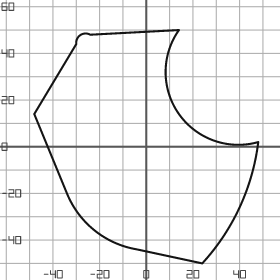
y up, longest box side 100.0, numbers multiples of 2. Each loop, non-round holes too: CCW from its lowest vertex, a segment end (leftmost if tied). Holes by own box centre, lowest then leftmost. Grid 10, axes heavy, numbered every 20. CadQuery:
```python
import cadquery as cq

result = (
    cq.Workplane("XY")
    .moveTo(24.0, -50.0)
    .threePointArc((40.0, -26.0), (48.0, 2.0))
    .threePointArc((14.0, 14.0), (14.0, 50.0))
    .lineTo(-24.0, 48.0)
    .threePointArc((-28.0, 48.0), (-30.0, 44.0))
    .lineTo(-48.0, 14.0)
    .lineTo(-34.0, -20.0)
    .threePointArc((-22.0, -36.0), (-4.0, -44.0))
    .close()
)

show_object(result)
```